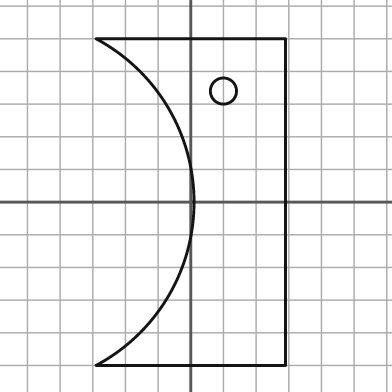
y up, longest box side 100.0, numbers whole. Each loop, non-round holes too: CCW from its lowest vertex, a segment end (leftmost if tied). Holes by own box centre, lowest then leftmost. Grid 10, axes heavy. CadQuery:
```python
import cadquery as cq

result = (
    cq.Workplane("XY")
    .moveTo(-29.0, -50.0)
    .lineTo(29.0, -50.0)
    .lineTo(29.0, 50.0)
    .lineTo(-29.0, 50.0)
    .threePointArc((1.0, 0.0), (-29.0, -50.0))
    .close()
    .moveTo(10.0, 34.0)
    .circle(4.0)
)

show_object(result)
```